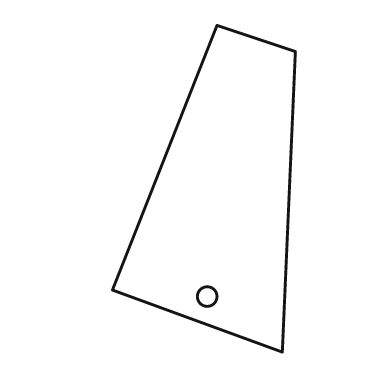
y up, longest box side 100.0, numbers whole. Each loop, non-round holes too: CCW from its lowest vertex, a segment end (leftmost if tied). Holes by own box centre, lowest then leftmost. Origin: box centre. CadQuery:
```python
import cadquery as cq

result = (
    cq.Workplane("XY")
    .moveTo(24.0, -50.0)
    .lineTo(28.0, 42.0)
    .lineTo(4.0, 50.0)
    .lineTo(-28.0, -31.0)
    .close()
    .moveTo(1.0, -33.0)
    .circle(3.0)
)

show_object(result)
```